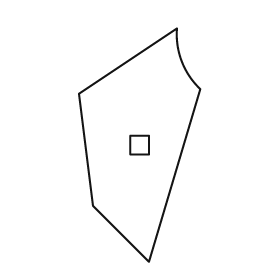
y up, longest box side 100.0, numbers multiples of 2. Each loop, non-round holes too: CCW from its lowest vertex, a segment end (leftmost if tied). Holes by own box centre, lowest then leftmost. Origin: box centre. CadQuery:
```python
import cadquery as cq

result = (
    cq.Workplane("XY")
    .moveTo(4.0, -50.0)
    .lineTo(26.0, 24.0)
    .threePointArc((18.0, 36.0), (16.0, 50.0))
    .lineTo(-26.0, 22.0)
    .lineTo(-20.0, -26.0)
    .close()
    .moveTo(-4.0, -4.0)
    .lineTo(4.0, -4.0)
    .lineTo(4.0, 4.0)
    .lineTo(-4.0, 4.0)
    .close()
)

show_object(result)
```